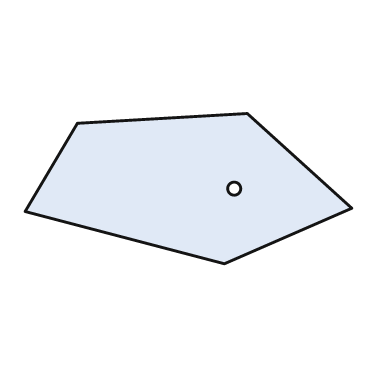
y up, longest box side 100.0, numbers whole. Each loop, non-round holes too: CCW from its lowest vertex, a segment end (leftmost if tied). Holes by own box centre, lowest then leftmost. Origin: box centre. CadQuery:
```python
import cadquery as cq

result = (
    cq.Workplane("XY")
    .moveTo(11.0, -23.0)
    .lineTo(50.0, -6.0)
    .lineTo(18.0, 23.0)
    .lineTo(-34.0, 20.0)
    .lineTo(-50.0, -7.0)
    .close()
    .moveTo(14.0, 0.0)
    .circle(2.0)
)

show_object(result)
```